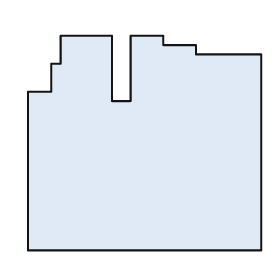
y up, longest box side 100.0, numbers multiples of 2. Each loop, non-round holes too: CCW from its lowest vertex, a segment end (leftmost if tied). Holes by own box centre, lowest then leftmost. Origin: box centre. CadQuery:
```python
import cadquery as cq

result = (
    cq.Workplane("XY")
    .moveTo(-50.0, -46.0)
    .lineTo(50.0, -46.0)
    .lineTo(50.0, 38.0)
    .lineTo(22.0, 38.0)
    .lineTo(22.0, 42.0)
    .lineTo(8.0, 42.0)
    .lineTo(8.0, 46.0)
    .lineTo(-6.0, 46.0)
    .lineTo(-6.0, 18.0)
    .lineTo(-14.0, 18.0)
    .lineTo(-14.0, 46.0)
    .lineTo(-36.0, 46.0)
    .lineTo(-36.0, 34.0)
    .lineTo(-40.0, 34.0)
    .lineTo(-40.0, 22.0)
    .lineTo(-50.0, 22.0)
    .close()
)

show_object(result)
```